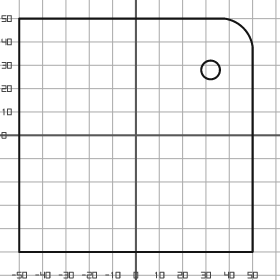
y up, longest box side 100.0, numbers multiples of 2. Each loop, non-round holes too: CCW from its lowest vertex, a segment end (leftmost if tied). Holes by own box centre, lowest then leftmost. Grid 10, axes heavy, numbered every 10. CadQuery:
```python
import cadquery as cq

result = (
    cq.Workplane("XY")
    .moveTo(-50.0, -50.0)
    .lineTo(50.0, -50.0)
    .lineTo(50.0, 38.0)
    .threePointArc((46.0, 46.0), (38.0, 50.0))
    .lineTo(-50.0, 50.0)
    .close()
    .moveTo(32.0, 28.0)
    .circle(4.0)
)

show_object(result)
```